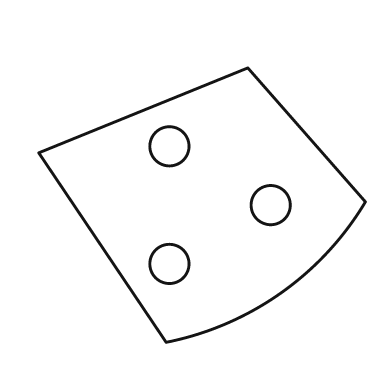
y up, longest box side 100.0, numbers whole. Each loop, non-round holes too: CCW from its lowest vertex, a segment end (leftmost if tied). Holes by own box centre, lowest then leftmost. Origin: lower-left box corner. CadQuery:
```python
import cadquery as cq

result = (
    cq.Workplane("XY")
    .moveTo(39.0, 0.0)
    .threePointArc((74.0, 15.0), (100.0, 43.0))
    .lineTo(64.0, 84.0)
    .lineTo(0.0, 58.0)
    .close()
    .moveTo(40.0, 24.0)
    .circle(6.0)
    .moveTo(71.0, 42.0)
    .circle(6.0)
    .moveTo(40.0, 60.0)
    .circle(6.0)
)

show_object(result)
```